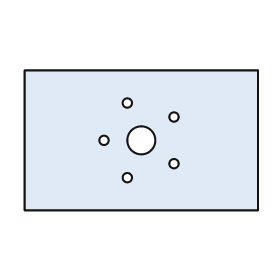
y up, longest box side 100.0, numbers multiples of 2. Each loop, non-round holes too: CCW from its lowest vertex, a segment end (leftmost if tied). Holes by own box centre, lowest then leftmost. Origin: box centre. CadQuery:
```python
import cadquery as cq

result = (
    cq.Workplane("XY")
    .moveTo(-50.0, -30.0)
    .lineTo(50.0, -30.0)
    .lineTo(50.0, 30.0)
    .lineTo(-50.0, 30.0)
    .close()
    .moveTo(-6.0, -16.0)
    .circle(2.0)
    .moveTo(14.0, -10.0)
    .circle(2.0)
    .moveTo(-16.0, 0.0)
    .circle(2.0)
    .moveTo(0.0, 0.0)
    .circle(6.0)
    .moveTo(14.0, 10.0)
    .circle(2.0)
    .moveTo(-6.0, 16.0)
    .circle(2.0)
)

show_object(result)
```